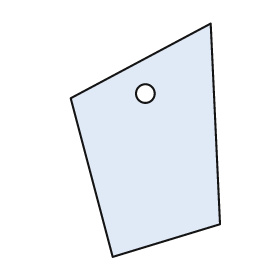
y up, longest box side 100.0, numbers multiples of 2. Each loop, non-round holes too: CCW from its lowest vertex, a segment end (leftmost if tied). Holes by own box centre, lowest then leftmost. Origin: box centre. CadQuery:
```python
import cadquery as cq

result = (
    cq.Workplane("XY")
    .moveTo(-14.0, -50.0)
    .lineTo(32.0, -36.0)
    .lineTo(28.0, 50.0)
    .lineTo(-32.0, 18.0)
    .close()
    .moveTo(0.0, 20.0)
    .circle(4.0)
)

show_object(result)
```